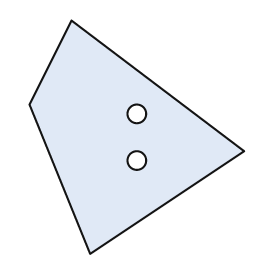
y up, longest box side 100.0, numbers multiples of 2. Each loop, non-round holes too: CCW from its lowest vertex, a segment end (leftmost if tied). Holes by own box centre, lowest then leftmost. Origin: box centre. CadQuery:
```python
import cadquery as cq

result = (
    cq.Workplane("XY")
    .moveTo(-20.0, -50.0)
    .lineTo(46.0, -6.0)
    .lineTo(-28.0, 50.0)
    .lineTo(-46.0, 14.0)
    .close()
    .moveTo(0.0, -10.0)
    .circle(4.0)
    .moveTo(0.0, 10.0)
    .circle(4.0)
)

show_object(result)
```